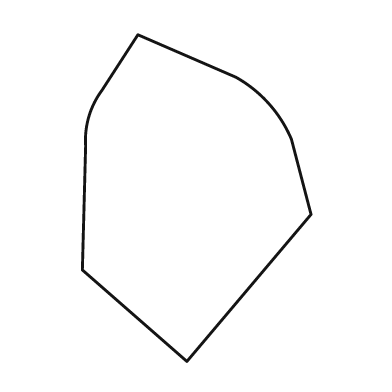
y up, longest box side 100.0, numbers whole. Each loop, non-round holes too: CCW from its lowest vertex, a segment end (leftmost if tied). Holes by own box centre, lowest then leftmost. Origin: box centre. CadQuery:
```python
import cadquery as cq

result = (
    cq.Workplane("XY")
    .moveTo(-3.0, -50.0)
    .lineTo(35.0, -5.0)
    .lineTo(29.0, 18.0)
    .threePointArc((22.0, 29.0), (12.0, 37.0))
    .lineTo(-18.0, 50.0)
    .lineTo(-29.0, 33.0)
    .threePointArc((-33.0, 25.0), (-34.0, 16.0))
    .lineTo(-35.0, -22.0)
    .close()
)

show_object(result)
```